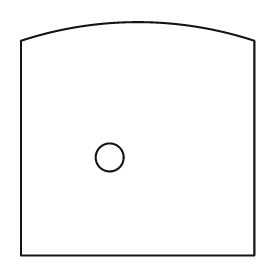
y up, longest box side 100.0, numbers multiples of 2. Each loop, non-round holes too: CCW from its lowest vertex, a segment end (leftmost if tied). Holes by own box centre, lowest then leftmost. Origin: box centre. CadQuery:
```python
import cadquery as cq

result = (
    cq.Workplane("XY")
    .moveTo(-50.0, -50.0)
    .lineTo(50.0, -50.0)
    .lineTo(50.0, 42.0)
    .threePointArc((0.0, 50.0), (-50.0, 42.0))
    .close()
    .moveTo(-12.0, -8.0)
    .circle(6.0)
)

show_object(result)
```